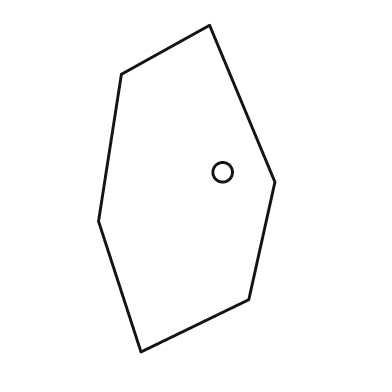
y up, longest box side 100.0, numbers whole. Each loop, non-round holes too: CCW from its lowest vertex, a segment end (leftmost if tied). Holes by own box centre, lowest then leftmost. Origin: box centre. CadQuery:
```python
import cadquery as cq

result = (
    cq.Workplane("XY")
    .moveTo(-14.0, -50.0)
    .lineTo(19.0, -34.0)
    .lineTo(27.0, 2.0)
    .lineTo(7.0, 50.0)
    .lineTo(-20.0, 35.0)
    .lineTo(-27.0, -10.0)
    .close()
    .moveTo(11.0, 5.0)
    .circle(3.0)
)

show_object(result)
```